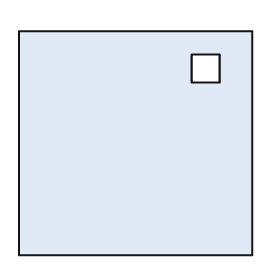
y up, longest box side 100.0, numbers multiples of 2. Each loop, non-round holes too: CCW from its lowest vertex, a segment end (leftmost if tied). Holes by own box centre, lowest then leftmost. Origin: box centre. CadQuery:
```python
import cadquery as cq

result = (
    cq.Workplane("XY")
    .moveTo(-50.0, -48.0)
    .lineTo(50.0, -48.0)
    .lineTo(50.0, 48.0)
    .lineTo(-50.0, 48.0)
    .close()
    .moveTo(24.0, 26.0)
    .lineTo(36.0, 26.0)
    .lineTo(36.0, 38.0)
    .lineTo(24.0, 38.0)
    .close()
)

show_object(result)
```